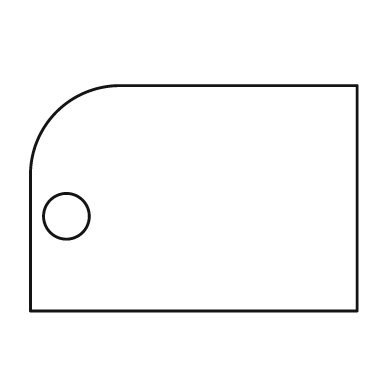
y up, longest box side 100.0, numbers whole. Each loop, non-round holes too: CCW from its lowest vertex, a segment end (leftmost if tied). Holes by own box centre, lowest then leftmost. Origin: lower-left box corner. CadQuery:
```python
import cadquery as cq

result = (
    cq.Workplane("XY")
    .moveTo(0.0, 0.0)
    .lineTo(100.0, 0.0)
    .lineTo(100.0, 69.0)
    .lineTo(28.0, 69.0)
    .threePointArc((8.0, 61.0), (0.0, 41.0))
    .close()
    .moveTo(11.0, 29.0)
    .circle(7.0)
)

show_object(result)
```